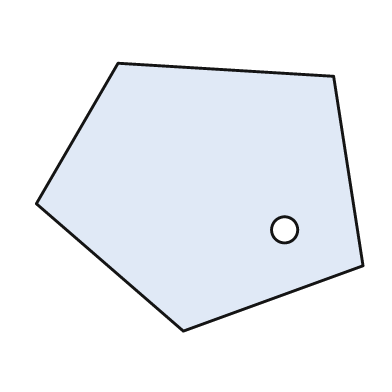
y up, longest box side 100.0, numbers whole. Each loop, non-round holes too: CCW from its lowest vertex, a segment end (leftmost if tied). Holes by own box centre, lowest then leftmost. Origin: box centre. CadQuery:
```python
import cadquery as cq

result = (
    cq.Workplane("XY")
    .moveTo(-5.0, -41.0)
    .lineTo(50.0, -21.0)
    .lineTo(41.0, 37.0)
    .lineTo(-25.0, 41.0)
    .lineTo(-50.0, -2.0)
    .close()
    .moveTo(26.0, -10.0)
    .circle(4.0)
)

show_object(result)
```